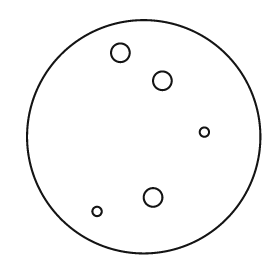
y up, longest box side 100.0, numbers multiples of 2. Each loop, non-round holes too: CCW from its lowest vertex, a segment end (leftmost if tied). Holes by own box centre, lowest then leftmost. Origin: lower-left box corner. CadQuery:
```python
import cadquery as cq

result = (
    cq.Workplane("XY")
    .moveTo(50.0, 50.0)
    .circle(50.0)
    .moveTo(30.0, 18.0)
    .circle(2.0)
    .moveTo(54.0, 24.0)
    .circle(4.0)
    .moveTo(76.0, 52.0)
    .circle(2.0)
    .moveTo(58.0, 74.0)
    .circle(4.0)
    .moveTo(40.0, 86.0)
    .circle(4.0)
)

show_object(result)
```